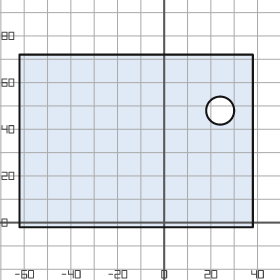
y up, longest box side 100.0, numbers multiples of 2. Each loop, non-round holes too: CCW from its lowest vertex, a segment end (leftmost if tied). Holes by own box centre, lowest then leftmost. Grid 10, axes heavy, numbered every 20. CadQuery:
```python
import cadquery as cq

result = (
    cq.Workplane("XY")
    .moveTo(-62.0, -2.0)
    .lineTo(38.0, -2.0)
    .lineTo(38.0, 72.0)
    .lineTo(-62.0, 72.0)
    .close()
    .moveTo(24.0, 48.0)
    .circle(6.0)
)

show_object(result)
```